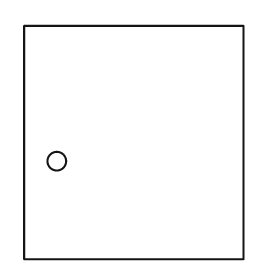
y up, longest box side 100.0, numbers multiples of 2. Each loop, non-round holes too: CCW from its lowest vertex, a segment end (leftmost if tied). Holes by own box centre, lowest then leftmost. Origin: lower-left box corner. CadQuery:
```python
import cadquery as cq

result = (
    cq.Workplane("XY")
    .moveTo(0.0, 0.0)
    .lineTo(94.0, 0.0)
    .lineTo(94.0, 100.0)
    .lineTo(0.0, 100.0)
    .close()
    .moveTo(14.0, 42.0)
    .circle(4.0)
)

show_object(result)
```